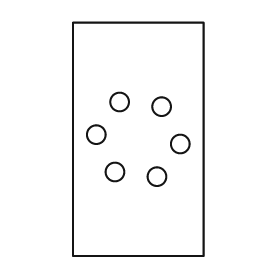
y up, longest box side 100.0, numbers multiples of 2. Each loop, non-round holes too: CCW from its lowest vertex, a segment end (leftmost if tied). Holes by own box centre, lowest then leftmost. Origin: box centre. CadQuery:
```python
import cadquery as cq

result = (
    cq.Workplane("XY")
    .moveTo(-28.0, -50.0)
    .lineTo(28.0, -50.0)
    .lineTo(28.0, 50.0)
    .lineTo(-28.0, 50.0)
    .close()
    .moveTo(8.0, -16.0)
    .circle(4.0)
    .moveTo(-10.0, -14.0)
    .circle(4.0)
    .moveTo(18.0, -2.0)
    .circle(4.0)
    .moveTo(-18.0, 2.0)
    .circle(4.0)
    .moveTo(10.0, 14.0)
    .circle(4.0)
    .moveTo(-8.0, 16.0)
    .circle(4.0)
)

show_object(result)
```